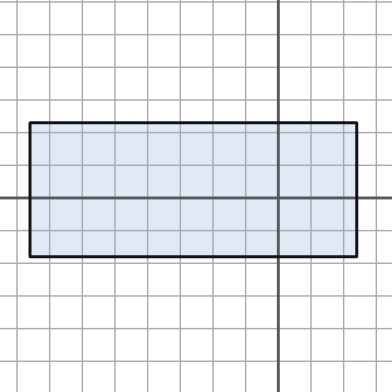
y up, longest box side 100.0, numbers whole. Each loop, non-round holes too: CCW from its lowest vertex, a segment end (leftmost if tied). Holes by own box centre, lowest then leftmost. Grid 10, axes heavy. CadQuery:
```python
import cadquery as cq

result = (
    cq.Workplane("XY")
    .moveTo(-76.0, -18.0)
    .lineTo(24.0, -18.0)
    .lineTo(24.0, 23.0)
    .lineTo(-76.0, 23.0)
    .close()
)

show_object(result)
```